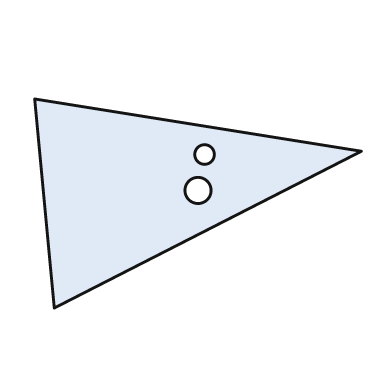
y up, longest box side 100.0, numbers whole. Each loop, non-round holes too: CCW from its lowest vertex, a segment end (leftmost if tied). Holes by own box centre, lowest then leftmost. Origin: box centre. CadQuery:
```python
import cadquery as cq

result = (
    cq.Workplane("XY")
    .moveTo(-44.0, -32.0)
    .lineTo(50.0, 16.0)
    .lineTo(-50.0, 32.0)
    .close()
    .moveTo(0.0, 4.0)
    .circle(4.0)
    .moveTo(2.0, 15.0)
    .circle(3.0)
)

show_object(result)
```